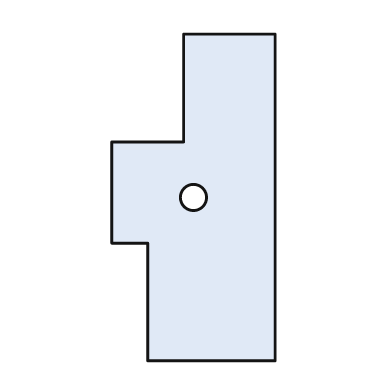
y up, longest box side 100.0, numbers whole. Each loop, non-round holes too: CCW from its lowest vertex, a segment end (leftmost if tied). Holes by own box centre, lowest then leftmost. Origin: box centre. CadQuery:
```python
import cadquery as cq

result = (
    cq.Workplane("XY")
    .moveTo(-14.0, -50.0)
    .lineTo(25.0, -50.0)
    .lineTo(25.0, 50.0)
    .lineTo(-3.0, 50.0)
    .lineTo(-3.0, 17.0)
    .lineTo(-25.0, 17.0)
    .lineTo(-25.0, -14.0)
    .lineTo(-14.0, -14.0)
    .close()
    .moveTo(0.0, 0.0)
    .circle(4.0)
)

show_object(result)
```